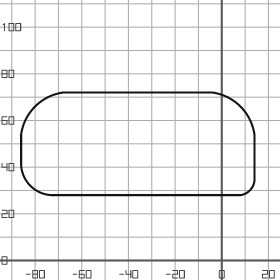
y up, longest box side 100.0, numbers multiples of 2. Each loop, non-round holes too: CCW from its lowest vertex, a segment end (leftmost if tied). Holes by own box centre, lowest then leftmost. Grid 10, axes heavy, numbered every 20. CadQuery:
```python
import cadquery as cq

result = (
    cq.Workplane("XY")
    .moveTo(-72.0, 28.0)
    .lineTo(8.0, 28.0)
    .threePointArc((12.0, 30.0), (14.0, 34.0))
    .lineTo(14.0, 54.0)
    .threePointArc((8.0, 66.0), (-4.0, 72.0))
    .lineTo(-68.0, 72.0)
    .threePointArc((-80.0, 66.0), (-86.0, 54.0))
    .lineTo(-86.0, 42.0)
    .threePointArc((-82.0, 32.0), (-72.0, 28.0))
    .close()
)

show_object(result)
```